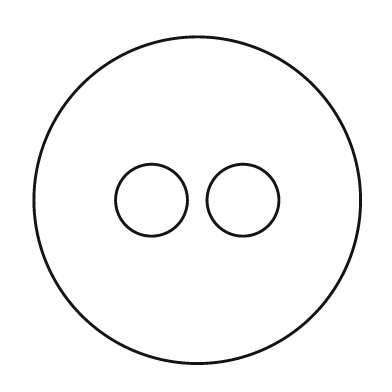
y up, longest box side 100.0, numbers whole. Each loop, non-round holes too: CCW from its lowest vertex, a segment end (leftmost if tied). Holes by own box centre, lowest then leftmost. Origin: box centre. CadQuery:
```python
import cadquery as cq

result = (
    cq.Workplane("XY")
    .moveTo(0.0, 0.0)
    .circle(50.0)
    .moveTo(-14.0, 0.0)
    .circle(11.0)
    .moveTo(14.0, 0.0)
    .circle(11.0)
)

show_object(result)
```